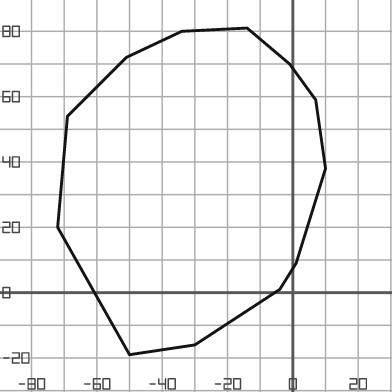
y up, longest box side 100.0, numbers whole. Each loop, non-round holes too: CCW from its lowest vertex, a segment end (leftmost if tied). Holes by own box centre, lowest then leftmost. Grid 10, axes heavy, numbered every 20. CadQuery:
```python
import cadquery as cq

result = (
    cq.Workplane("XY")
    .moveTo(-50.0, -19.0)
    .lineTo(-30.0, -16.0)
    .lineTo(-4.0, 1.0)
    .lineTo(1.0, 9.0)
    .lineTo(10.0, 38.0)
    .lineTo(7.0, 59.0)
    .lineTo(-1.0, 70.0)
    .lineTo(-14.0, 81.0)
    .lineTo(-34.0, 80.0)
    .lineTo(-51.0, 72.0)
    .lineTo(-69.0, 54.0)
    .lineTo(-72.0, 20.0)
    .close()
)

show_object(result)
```